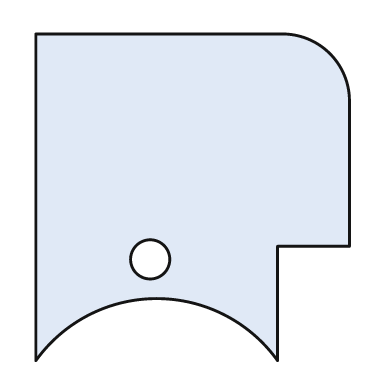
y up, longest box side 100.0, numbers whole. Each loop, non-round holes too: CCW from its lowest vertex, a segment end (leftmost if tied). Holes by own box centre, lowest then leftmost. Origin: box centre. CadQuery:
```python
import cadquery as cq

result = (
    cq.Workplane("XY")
    .moveTo(-48.0, -50.0)
    .threePointArc((-11.0, -31.0), (26.0, -50.0))
    .lineTo(26.0, -15.0)
    .lineTo(48.0, -15.0)
    .lineTo(48.0, 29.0)
    .threePointArc((42.0, 44.0), (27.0, 50.0))
    .lineTo(-48.0, 50.0)
    .close()
    .moveTo(-13.0, -19.0)
    .circle(6.0)
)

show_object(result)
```